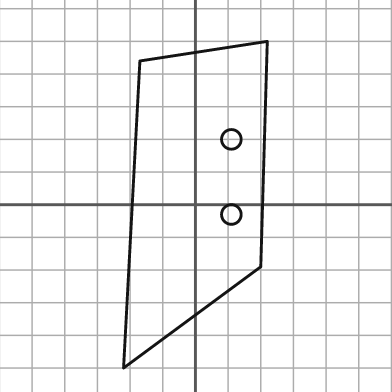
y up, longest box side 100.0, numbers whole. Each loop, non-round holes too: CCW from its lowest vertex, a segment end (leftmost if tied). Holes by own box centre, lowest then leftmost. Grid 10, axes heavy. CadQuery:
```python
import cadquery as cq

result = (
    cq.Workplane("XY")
    .moveTo(-22.0, -50.0)
    .lineTo(20.0, -19.0)
    .lineTo(22.0, 50.0)
    .lineTo(-17.0, 44.0)
    .close()
    .moveTo(11.0, -3.0)
    .circle(3.0)
    .moveTo(11.0, 20.0)
    .circle(3.0)
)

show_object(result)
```